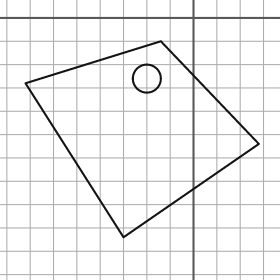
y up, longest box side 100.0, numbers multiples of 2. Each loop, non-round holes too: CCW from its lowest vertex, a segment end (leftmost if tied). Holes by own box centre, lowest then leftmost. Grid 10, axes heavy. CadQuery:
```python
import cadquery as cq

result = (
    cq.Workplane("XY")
    .moveTo(-30.0, -94.0)
    .lineTo(28.0, -54.0)
    .lineTo(-14.0, -10.0)
    .lineTo(-72.0, -28.0)
    .close()
    .moveTo(-20.0, -26.0)
    .circle(6.0)
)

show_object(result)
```